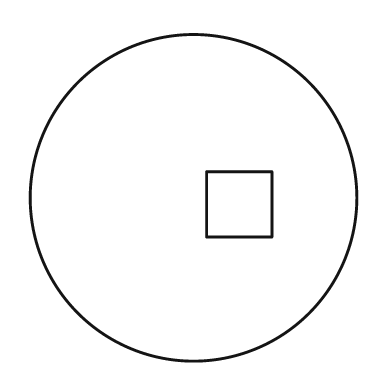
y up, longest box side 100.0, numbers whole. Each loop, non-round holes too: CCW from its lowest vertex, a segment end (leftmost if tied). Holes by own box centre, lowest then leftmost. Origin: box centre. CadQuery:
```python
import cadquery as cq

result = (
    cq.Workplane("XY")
    .moveTo(0.0, 0.0)
    .circle(50.0)
    .moveTo(4.0, -12.0)
    .lineTo(24.0, -12.0)
    .lineTo(24.0, 8.0)
    .lineTo(4.0, 8.0)
    .close()
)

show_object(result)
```